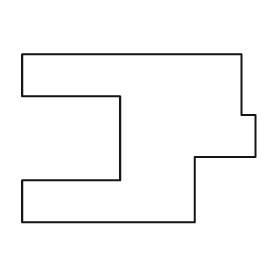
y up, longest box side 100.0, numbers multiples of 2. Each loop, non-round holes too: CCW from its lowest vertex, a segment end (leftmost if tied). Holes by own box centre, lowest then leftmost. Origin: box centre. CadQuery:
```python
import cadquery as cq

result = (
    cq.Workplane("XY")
    .moveTo(-50.0, -36.0)
    .lineTo(24.0, -36.0)
    .lineTo(24.0, -8.0)
    .lineTo(50.0, -8.0)
    .lineTo(50.0, 10.0)
    .lineTo(44.0, 10.0)
    .lineTo(44.0, 36.0)
    .lineTo(-50.0, 36.0)
    .lineTo(-50.0, 18.0)
    .lineTo(-8.0, 18.0)
    .lineTo(-8.0, -18.0)
    .lineTo(-50.0, -18.0)
    .close()
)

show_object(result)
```